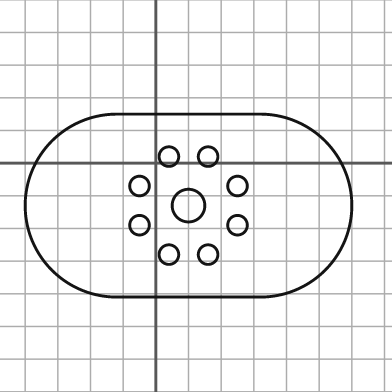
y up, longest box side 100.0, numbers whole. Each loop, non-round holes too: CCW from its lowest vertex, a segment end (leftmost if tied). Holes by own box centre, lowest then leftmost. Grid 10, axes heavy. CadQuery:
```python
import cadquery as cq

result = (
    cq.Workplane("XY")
    .moveTo(-12.0, -41.0)
    .lineTo(32.0, -41.0)
    .threePointArc((60.0, -13.0), (32.0, 15.0))
    .lineTo(-12.0, 15.0)
    .threePointArc((-40.0, -13.0), (-12.0, -41.0))
    .close()
    .moveTo(4.0, -28.0)
    .circle(3.0)
    .moveTo(16.0, -28.0)
    .circle(3.0)
    .moveTo(-5.0, -19.0)
    .circle(3.0)
    .moveTo(25.0, -19.0)
    .circle(3.0)
    .moveTo(10.0, -13.0)
    .circle(5.0)
    .moveTo(-5.0, -7.0)
    .circle(3.0)
    .moveTo(25.0, -7.0)
    .circle(3.0)
    .moveTo(4.0, 2.0)
    .circle(3.0)
    .moveTo(16.0, 2.0)
    .circle(3.0)
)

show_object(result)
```